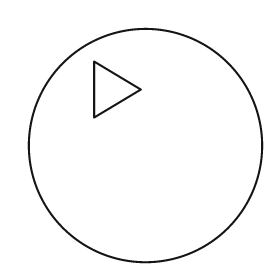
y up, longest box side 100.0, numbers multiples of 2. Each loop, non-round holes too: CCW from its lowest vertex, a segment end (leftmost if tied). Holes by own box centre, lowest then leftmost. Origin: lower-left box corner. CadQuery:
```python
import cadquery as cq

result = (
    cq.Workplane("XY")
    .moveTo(50.0, 50.0)
    .circle(50.0)
    .moveTo(28.0, 62.0)
    .lineTo(48.0, 74.0)
    .lineTo(28.0, 86.0)
    .close()
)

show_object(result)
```